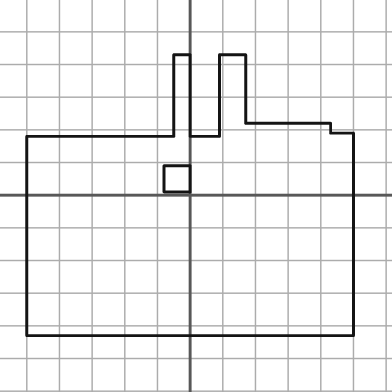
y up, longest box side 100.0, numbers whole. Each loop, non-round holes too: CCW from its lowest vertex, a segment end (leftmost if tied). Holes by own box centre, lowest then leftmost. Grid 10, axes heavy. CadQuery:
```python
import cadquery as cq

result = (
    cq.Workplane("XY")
    .moveTo(-50.0, -43.0)
    .lineTo(50.0, -43.0)
    .lineTo(50.0, 19.0)
    .lineTo(43.0, 19.0)
    .lineTo(43.0, 22.0)
    .lineTo(17.0, 22.0)
    .lineTo(17.0, 43.0)
    .lineTo(9.0, 43.0)
    .lineTo(9.0, 18.0)
    .lineTo(0.0, 18.0)
    .lineTo(0.0, 43.0)
    .lineTo(-5.0, 43.0)
    .lineTo(-5.0, 18.0)
    .lineTo(-50.0, 18.0)
    .close()
    .moveTo(-8.0, 1.0)
    .lineTo(0.0, 1.0)
    .lineTo(0.0, 9.0)
    .lineTo(-8.0, 9.0)
    .close()
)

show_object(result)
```